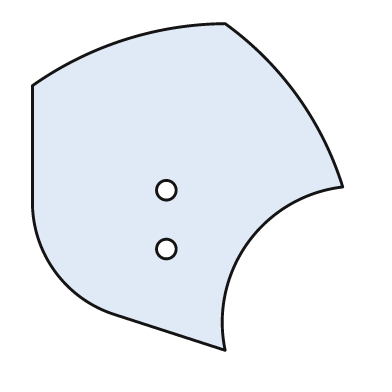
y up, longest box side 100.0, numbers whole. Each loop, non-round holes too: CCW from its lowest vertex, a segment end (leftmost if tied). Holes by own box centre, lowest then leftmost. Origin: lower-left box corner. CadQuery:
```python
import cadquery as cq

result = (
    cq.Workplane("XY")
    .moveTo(59.0, 0.0)
    .threePointArc((66.0, 33.0), (95.0, 50.0))
    .threePointArc((81.0, 78.0), (59.0, 100.0))
    .threePointArc((28.0, 95.0), (0.0, 81.0))
    .lineTo(0.0, 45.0)
    .threePointArc((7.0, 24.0), (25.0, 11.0))
    .close()
    .moveTo(41.0, 31.0)
    .circle(3.0)
    .moveTo(41.0, 49.0)
    .circle(3.0)
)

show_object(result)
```